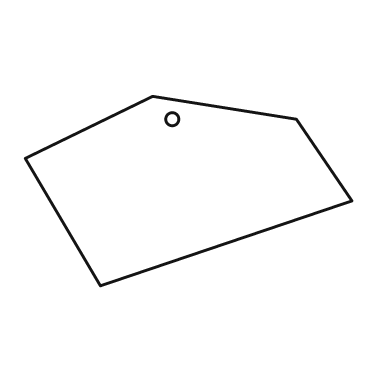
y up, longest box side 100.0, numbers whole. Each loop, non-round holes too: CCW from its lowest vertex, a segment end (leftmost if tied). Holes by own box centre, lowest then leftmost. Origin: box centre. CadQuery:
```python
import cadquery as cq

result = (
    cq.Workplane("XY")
    .moveTo(-27.0, -29.0)
    .lineTo(50.0, -3.0)
    .lineTo(33.0, 22.0)
    .lineTo(-11.0, 29.0)
    .lineTo(-50.0, 10.0)
    .close()
    .moveTo(-5.0, 22.0)
    .circle(2.0)
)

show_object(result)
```